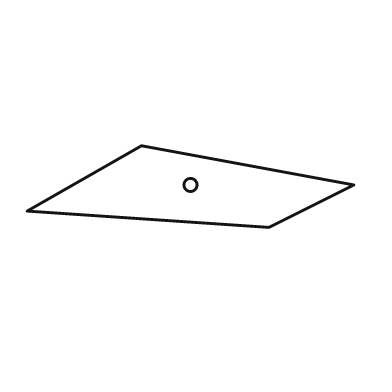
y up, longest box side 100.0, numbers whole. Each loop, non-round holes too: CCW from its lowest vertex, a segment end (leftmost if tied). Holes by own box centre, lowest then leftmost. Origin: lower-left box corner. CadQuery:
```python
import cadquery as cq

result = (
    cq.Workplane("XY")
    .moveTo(74.0, 0.0)
    .lineTo(100.0, 13.0)
    .lineTo(35.0, 25.0)
    .lineTo(0.0, 5.0)
    .close()
    .moveTo(50.0, 13.0)
    .circle(2.0)
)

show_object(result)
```